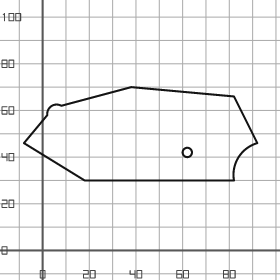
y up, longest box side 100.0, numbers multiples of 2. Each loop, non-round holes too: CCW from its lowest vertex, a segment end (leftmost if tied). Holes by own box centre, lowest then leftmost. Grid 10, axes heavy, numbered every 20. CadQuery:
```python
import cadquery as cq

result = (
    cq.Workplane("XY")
    .moveTo(18.0, 30.0)
    .lineTo(82.0, 30.0)
    .threePointArc((84.0, 40.0), (92.0, 46.0))
    .lineTo(82.0, 66.0)
    .lineTo(38.0, 70.0)
    .lineTo(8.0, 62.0)
    .threePointArc((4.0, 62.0), (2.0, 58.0))
    .lineTo(-8.0, 46.0)
    .close()
    .moveTo(62.0, 42.0)
    .circle(2.0)
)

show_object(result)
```